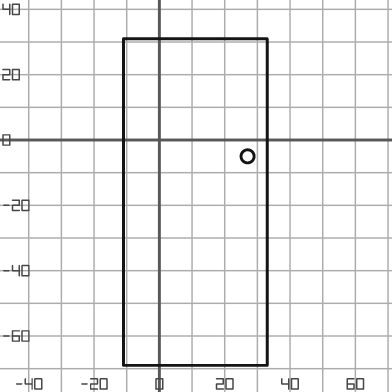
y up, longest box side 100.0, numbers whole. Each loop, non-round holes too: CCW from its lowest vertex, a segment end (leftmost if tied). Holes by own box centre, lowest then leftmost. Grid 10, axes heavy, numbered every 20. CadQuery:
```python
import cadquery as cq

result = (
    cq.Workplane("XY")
    .moveTo(-11.0, -69.0)
    .lineTo(33.0, -69.0)
    .lineTo(33.0, 31.0)
    .lineTo(-11.0, 31.0)
    .close()
    .moveTo(27.0, -5.0)
    .circle(2.0)
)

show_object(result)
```